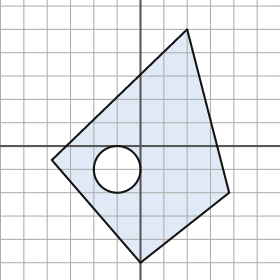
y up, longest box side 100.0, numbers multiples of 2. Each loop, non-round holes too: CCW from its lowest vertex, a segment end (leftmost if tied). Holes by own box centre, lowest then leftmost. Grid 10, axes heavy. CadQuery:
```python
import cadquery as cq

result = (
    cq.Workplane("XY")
    .moveTo(0.0, -50.0)
    .lineTo(38.0, -20.0)
    .lineTo(20.0, 50.0)
    .lineTo(-38.0, -6.0)
    .close()
    .moveTo(-10.0, -10.0)
    .circle(10.0)
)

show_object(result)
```